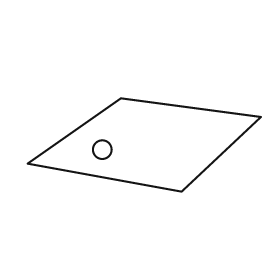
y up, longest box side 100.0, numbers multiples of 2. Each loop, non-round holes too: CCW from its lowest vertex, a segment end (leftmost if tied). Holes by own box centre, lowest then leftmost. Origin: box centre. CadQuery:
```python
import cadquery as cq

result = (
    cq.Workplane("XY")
    .moveTo(16.0, -20.0)
    .lineTo(50.0, 12.0)
    .lineTo(-10.0, 20.0)
    .lineTo(-50.0, -8.0)
    .close()
    .moveTo(-18.0, -2.0)
    .circle(4.0)
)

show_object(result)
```